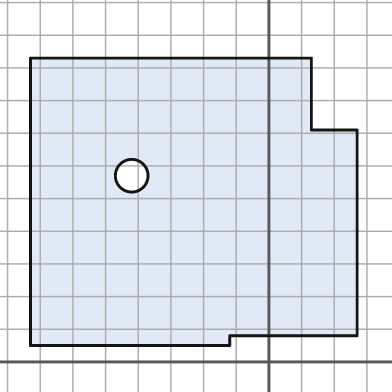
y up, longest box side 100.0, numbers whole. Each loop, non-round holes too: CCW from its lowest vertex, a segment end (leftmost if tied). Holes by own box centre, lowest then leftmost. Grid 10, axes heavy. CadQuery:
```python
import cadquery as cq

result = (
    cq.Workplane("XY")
    .moveTo(-73.0, 5.0)
    .lineTo(-12.0, 5.0)
    .lineTo(-12.0, 8.0)
    .lineTo(27.0, 8.0)
    .lineTo(27.0, 71.0)
    .lineTo(13.0, 71.0)
    .lineTo(13.0, 93.0)
    .lineTo(-73.0, 93.0)
    .close()
    .moveTo(-42.0, 57.0)
    .circle(5.0)
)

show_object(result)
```